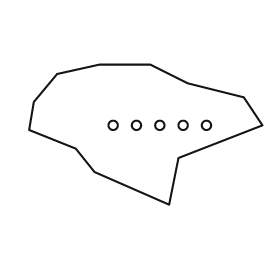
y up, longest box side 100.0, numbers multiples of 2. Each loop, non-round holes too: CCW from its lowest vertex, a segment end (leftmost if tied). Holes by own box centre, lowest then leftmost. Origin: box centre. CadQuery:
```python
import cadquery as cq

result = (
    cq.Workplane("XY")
    .moveTo(10.0, -30.0)
    .lineTo(14.0, -10.0)
    .lineTo(50.0, 4.0)
    .lineTo(42.0, 16.0)
    .lineTo(18.0, 22.0)
    .lineTo(2.0, 30.0)
    .lineTo(-20.0, 30.0)
    .lineTo(-38.0, 26.0)
    .lineTo(-48.0, 14.0)
    .lineTo(-50.0, 2.0)
    .lineTo(-30.0, -6.0)
    .lineTo(-22.0, -16.0)
    .close()
    .moveTo(-14.0, 4.0)
    .circle(2.0)
    .moveTo(-4.0, 4.0)
    .circle(2.0)
    .moveTo(6.0, 4.0)
    .circle(2.0)
    .moveTo(16.0, 4.0)
    .circle(2.0)
    .moveTo(26.0, 4.0)
    .circle(2.0)
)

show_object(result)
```